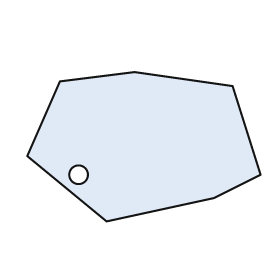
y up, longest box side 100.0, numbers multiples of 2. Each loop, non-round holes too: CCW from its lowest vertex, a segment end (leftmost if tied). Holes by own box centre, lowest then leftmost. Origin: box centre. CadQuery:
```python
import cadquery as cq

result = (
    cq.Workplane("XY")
    .moveTo(-16.0, -32.0)
    .lineTo(30.0, -22.0)
    .lineTo(50.0, -12.0)
    .lineTo(38.0, 26.0)
    .lineTo(-4.0, 32.0)
    .lineTo(-36.0, 28.0)
    .lineTo(-50.0, -4.0)
    .close()
    .moveTo(-28.0, -12.0)
    .circle(4.0)
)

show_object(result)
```